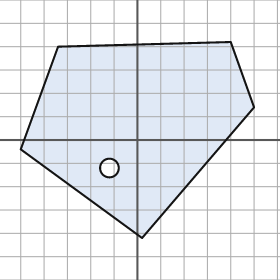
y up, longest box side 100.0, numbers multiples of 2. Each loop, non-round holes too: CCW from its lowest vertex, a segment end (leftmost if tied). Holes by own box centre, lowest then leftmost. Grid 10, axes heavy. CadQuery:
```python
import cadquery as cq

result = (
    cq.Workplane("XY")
    .moveTo(2.0, -42.0)
    .lineTo(50.0, 14.0)
    .lineTo(40.0, 42.0)
    .lineTo(-34.0, 40.0)
    .lineTo(-50.0, -4.0)
    .close()
    .moveTo(-12.0, -12.0)
    .circle(4.0)
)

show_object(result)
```